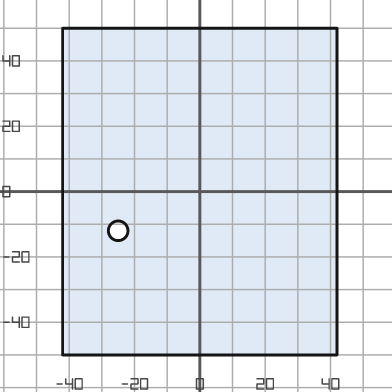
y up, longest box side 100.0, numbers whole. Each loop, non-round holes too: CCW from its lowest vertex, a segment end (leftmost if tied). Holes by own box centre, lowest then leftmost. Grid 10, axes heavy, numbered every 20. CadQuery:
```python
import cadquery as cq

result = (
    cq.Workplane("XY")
    .moveTo(-42.0, -50.0)
    .lineTo(42.0, -50.0)
    .lineTo(42.0, 50.0)
    .lineTo(-42.0, 50.0)
    .close()
    .moveTo(-25.0, -12.0)
    .circle(3.0)
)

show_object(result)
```